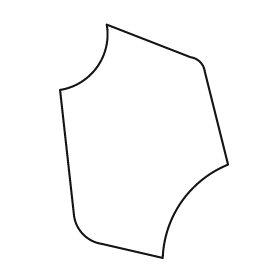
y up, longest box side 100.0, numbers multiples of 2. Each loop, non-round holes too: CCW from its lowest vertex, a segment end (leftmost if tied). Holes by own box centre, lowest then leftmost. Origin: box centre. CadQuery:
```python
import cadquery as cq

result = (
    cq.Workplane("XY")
    .moveTo(8.0, -50.0)
    .threePointArc((16.0, -26.0), (36.0, -10.0))
    .lineTo(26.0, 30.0)
    .threePointArc((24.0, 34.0), (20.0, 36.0))
    .lineTo(-16.0, 50.0)
    .threePointArc((-20.0, 32.0), (-36.0, 22.0))
    .lineTo(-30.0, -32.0)
    .threePointArc((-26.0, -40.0), (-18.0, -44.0))
    .close()
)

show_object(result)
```